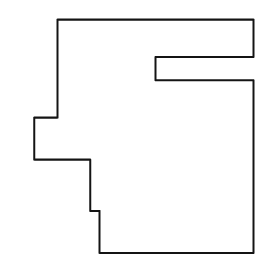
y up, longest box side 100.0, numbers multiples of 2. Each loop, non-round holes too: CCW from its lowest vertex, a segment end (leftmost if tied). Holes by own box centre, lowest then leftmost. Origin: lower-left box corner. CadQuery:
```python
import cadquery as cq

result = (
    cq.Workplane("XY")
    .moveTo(28.0, 0.0)
    .lineTo(94.0, 0.0)
    .lineTo(94.0, 74.0)
    .lineTo(52.0, 74.0)
    .lineTo(52.0, 84.0)
    .lineTo(94.0, 84.0)
    .lineTo(94.0, 100.0)
    .lineTo(10.0, 100.0)
    .lineTo(10.0, 58.0)
    .lineTo(0.0, 58.0)
    .lineTo(0.0, 40.0)
    .lineTo(24.0, 40.0)
    .lineTo(24.0, 18.0)
    .lineTo(28.0, 18.0)
    .close()
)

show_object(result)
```